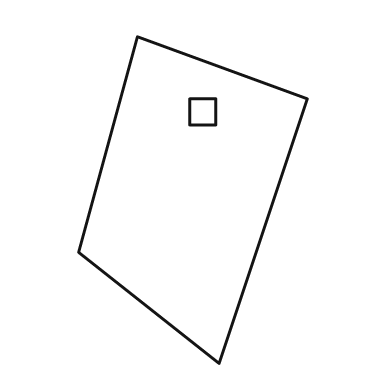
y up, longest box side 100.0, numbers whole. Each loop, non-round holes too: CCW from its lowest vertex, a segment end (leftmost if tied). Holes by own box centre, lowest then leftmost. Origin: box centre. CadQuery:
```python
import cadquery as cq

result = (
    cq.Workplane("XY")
    .moveTo(8.0, -50.0)
    .lineTo(35.0, 31.0)
    .lineTo(-17.0, 50.0)
    .lineTo(-35.0, -16.0)
    .close()
    .moveTo(-1.0, 23.0)
    .lineTo(7.0, 23.0)
    .lineTo(7.0, 31.0)
    .lineTo(-1.0, 31.0)
    .close()
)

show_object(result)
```